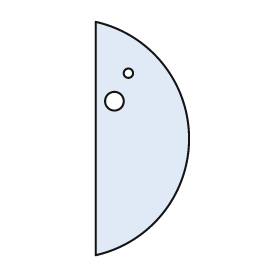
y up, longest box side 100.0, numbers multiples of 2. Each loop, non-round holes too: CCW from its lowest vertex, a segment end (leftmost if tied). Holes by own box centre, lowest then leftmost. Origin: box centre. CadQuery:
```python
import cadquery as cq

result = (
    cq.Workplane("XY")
    .moveTo(-20.0, -50.0)
    .threePointArc((20.0, 0.0), (-20.0, 50.0))
    .close()
    .moveTo(-12.0, 16.0)
    .circle(4.0)
    .moveTo(-6.0, 28.0)
    .circle(2.0)
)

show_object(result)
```